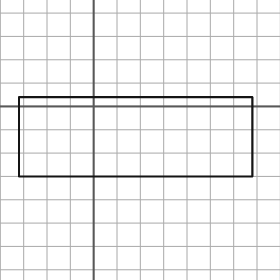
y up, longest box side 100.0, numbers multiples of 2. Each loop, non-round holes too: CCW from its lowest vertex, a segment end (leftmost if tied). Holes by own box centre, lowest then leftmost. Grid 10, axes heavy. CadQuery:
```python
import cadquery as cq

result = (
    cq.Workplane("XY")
    .moveTo(-32.0, -30.0)
    .lineTo(68.0, -30.0)
    .lineTo(68.0, 4.0)
    .lineTo(-32.0, 4.0)
    .close()
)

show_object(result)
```